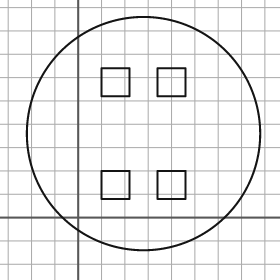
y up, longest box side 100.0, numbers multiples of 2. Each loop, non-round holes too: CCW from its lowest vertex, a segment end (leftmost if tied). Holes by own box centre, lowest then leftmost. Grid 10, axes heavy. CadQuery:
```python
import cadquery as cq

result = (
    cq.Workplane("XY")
    .moveTo(28.0, 36.0)
    .circle(50.0)
    .moveTo(10.0, 8.0)
    .lineTo(22.0, 8.0)
    .lineTo(22.0, 20.0)
    .lineTo(10.0, 20.0)
    .close()
    .moveTo(34.0, 8.0)
    .lineTo(46.0, 8.0)
    .lineTo(46.0, 20.0)
    .lineTo(34.0, 20.0)
    .close()
    .moveTo(10.0, 52.0)
    .lineTo(22.0, 52.0)
    .lineTo(22.0, 64.0)
    .lineTo(10.0, 64.0)
    .close()
    .moveTo(34.0, 52.0)
    .lineTo(46.0, 52.0)
    .lineTo(46.0, 64.0)
    .lineTo(34.0, 64.0)
    .close()
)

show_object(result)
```